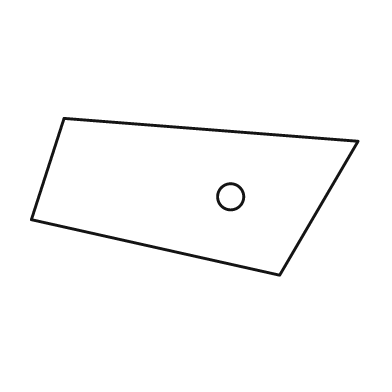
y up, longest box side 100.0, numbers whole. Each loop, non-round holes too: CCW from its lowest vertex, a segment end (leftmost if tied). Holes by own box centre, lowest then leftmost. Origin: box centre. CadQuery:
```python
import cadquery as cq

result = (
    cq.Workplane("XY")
    .moveTo(26.0, -24.0)
    .lineTo(50.0, 17.0)
    .lineTo(-40.0, 24.0)
    .lineTo(-50.0, -7.0)
    .close()
    .moveTo(11.0, 0.0)
    .circle(4.0)
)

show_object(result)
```